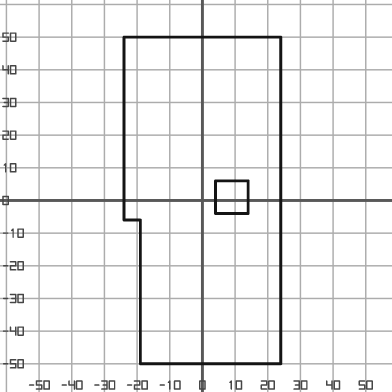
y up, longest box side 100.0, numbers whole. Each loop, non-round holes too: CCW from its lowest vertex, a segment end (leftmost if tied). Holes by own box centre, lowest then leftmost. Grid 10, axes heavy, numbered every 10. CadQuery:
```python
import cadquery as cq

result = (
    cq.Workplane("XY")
    .moveTo(-19.0, -50.0)
    .lineTo(24.0, -50.0)
    .lineTo(24.0, 50.0)
    .lineTo(-24.0, 50.0)
    .lineTo(-24.0, -6.0)
    .lineTo(-19.0, -6.0)
    .close()
    .moveTo(4.0, -4.0)
    .lineTo(14.0, -4.0)
    .lineTo(14.0, 6.0)
    .lineTo(4.0, 6.0)
    .close()
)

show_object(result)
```